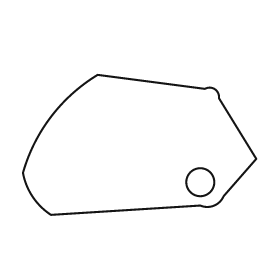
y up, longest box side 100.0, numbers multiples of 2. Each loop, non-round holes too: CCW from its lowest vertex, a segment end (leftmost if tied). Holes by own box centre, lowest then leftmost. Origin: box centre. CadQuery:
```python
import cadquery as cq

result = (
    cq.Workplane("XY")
    .moveTo(-38.0, -30.0)
    .lineTo(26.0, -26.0)
    .threePointArc((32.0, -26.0), (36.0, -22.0))
    .lineTo(50.0, -6.0)
    .lineTo(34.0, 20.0)
    .threePointArc((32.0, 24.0), (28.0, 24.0))
    .lineTo(-18.0, 30.0)
    .threePointArc((-38.0, 12.0), (-50.0, -12.0))
    .threePointArc((-46.0, -22.0), (-38.0, -30.0))
    .close()
    .moveTo(26.0, -16.0)
    .circle(6.0)
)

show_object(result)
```